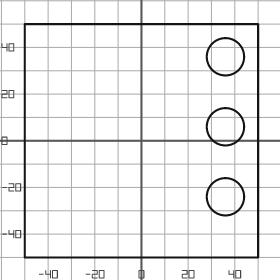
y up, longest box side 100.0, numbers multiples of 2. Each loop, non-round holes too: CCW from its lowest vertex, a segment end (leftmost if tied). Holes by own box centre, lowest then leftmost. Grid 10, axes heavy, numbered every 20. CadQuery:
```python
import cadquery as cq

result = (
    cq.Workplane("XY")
    .moveTo(-50.0, -50.0)
    .lineTo(50.0, -50.0)
    .lineTo(50.0, 50.0)
    .lineTo(-50.0, 50.0)
    .close()
    .moveTo(36.0, -24.0)
    .circle(8.0)
    .moveTo(36.0, 6.0)
    .circle(8.0)
    .moveTo(36.0, 36.0)
    .circle(8.0)
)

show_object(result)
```